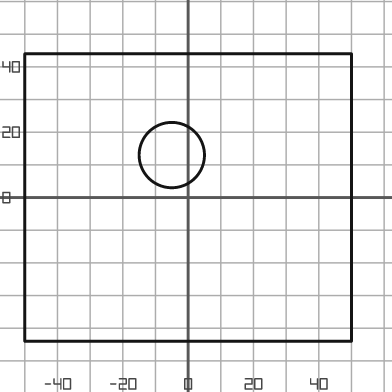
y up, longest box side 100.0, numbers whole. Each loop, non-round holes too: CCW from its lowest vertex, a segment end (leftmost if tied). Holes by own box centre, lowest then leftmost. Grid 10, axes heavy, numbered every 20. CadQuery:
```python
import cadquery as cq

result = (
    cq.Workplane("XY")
    .moveTo(-50.0, -44.0)
    .lineTo(50.0, -44.0)
    .lineTo(50.0, 44.0)
    .lineTo(-50.0, 44.0)
    .close()
    .moveTo(-5.0, 13.0)
    .circle(10.0)
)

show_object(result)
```